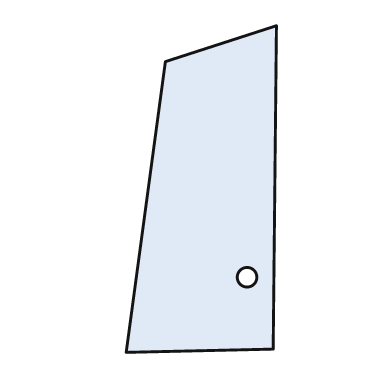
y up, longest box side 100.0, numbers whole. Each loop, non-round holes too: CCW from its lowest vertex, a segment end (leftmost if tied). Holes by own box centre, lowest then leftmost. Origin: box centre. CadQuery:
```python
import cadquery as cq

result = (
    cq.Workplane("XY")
    .moveTo(-23.0, -50.0)
    .lineTo(22.0, -49.0)
    .lineTo(23.0, 50.0)
    .lineTo(-11.0, 39.0)
    .close()
    .moveTo(14.0, -27.0)
    .circle(3.0)
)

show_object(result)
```